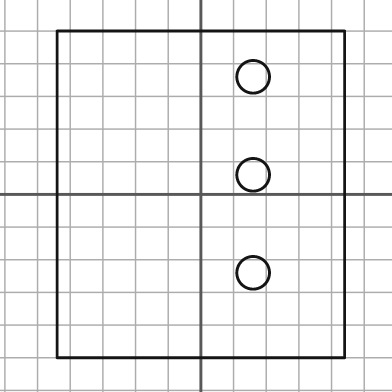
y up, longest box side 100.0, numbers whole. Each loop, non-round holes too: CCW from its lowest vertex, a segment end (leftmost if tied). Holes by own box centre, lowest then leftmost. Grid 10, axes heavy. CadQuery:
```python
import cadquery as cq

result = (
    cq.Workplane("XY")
    .moveTo(-44.0, -50.0)
    .lineTo(44.0, -50.0)
    .lineTo(44.0, 50.0)
    .lineTo(-44.0, 50.0)
    .close()
    .moveTo(16.0, -24.0)
    .circle(5.0)
    .moveTo(16.0, 6.0)
    .circle(5.0)
    .moveTo(16.0, 36.0)
    .circle(5.0)
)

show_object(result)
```